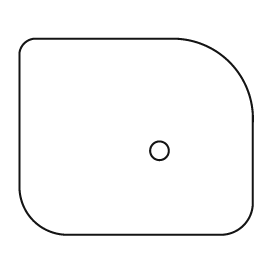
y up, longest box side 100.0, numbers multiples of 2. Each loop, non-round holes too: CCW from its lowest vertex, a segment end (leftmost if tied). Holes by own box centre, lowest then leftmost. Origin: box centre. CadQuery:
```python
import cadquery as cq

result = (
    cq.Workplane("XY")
    .moveTo(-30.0, -42.0)
    .lineTo(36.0, -42.0)
    .threePointArc((46.0, -38.0), (50.0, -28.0))
    .lineTo(50.0, 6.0)
    .threePointArc((40.0, 32.0), (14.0, 42.0))
    .lineTo(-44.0, 42.0)
    .threePointArc((-48.0, 40.0), (-50.0, 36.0))
    .lineTo(-50.0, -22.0)
    .threePointArc((-44.0, -36.0), (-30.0, -42.0))
    .close()
    .moveTo(10.0, -6.0)
    .circle(4.0)
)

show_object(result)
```